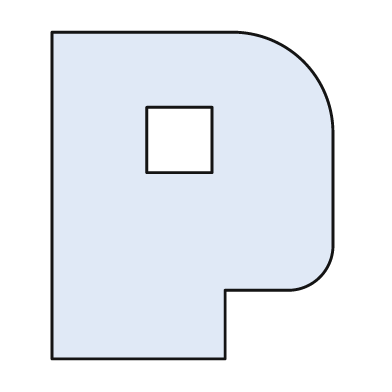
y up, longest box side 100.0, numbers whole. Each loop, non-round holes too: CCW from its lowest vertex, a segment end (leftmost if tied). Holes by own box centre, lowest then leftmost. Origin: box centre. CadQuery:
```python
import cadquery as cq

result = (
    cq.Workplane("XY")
    .moveTo(-43.0, -50.0)
    .lineTo(10.0, -50.0)
    .lineTo(10.0, -29.0)
    .lineTo(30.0, -29.0)
    .threePointArc((39.0, -25.0), (43.0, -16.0))
    .lineTo(43.0, 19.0)
    .threePointArc((34.0, 41.0), (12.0, 50.0))
    .lineTo(-43.0, 50.0)
    .close()
    .moveTo(-14.0, 7.0)
    .lineTo(6.0, 7.0)
    .lineTo(6.0, 27.0)
    .lineTo(-14.0, 27.0)
    .close()
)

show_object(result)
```